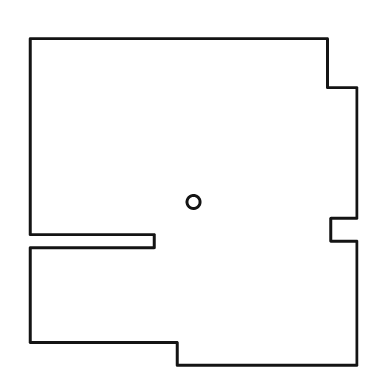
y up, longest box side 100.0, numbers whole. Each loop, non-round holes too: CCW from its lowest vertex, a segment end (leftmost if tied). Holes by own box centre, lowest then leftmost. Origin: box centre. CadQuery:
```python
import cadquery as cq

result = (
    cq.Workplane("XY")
    .moveTo(-5.0, -50.0)
    .lineTo(50.0, -50.0)
    .lineTo(50.0, -12.0)
    .lineTo(42.0, -12.0)
    .lineTo(42.0, -5.0)
    .lineTo(50.0, -5.0)
    .lineTo(50.0, 35.0)
    .lineTo(41.0, 35.0)
    .lineTo(41.0, 50.0)
    .lineTo(-50.0, 50.0)
    .lineTo(-50.0, -10.0)
    .lineTo(-12.0, -10.0)
    .lineTo(-12.0, -14.0)
    .lineTo(-50.0, -14.0)
    .lineTo(-50.0, -43.0)
    .lineTo(-5.0, -43.0)
    .close()
    .moveTo(0.0, 0.0)
    .circle(2.0)
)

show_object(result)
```